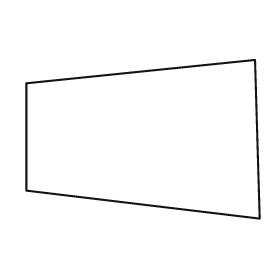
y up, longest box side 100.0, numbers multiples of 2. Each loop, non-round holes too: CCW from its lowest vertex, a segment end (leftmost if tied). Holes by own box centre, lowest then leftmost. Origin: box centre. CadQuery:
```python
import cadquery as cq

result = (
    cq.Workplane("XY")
    .moveTo(50.0, -34.0)
    .lineTo(48.0, 34.0)
    .lineTo(-50.0, 24.0)
    .lineTo(-50.0, -22.0)
    .close()
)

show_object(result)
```